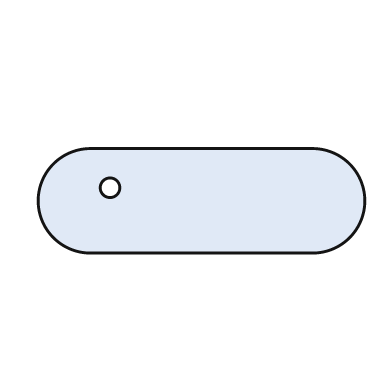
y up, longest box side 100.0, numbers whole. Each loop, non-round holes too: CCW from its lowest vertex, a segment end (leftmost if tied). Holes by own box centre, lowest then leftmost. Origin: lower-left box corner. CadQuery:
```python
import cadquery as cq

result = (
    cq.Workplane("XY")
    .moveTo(16.0, 0.0)
    .lineTo(84.0, 0.0)
    .threePointArc((100.0, 16.0), (84.0, 32.0))
    .lineTo(16.0, 32.0)
    .threePointArc((0.0, 16.0), (16.0, 0.0))
    .close()
    .moveTo(22.0, 20.0)
    .circle(3.0)
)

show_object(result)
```